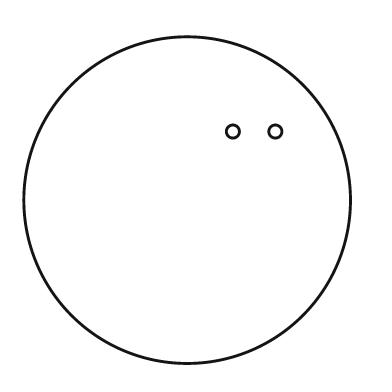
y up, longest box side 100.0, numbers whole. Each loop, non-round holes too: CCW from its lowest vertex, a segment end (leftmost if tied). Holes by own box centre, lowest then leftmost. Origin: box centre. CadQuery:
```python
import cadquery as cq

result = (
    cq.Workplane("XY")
    .moveTo(0.0, 0.0)
    .circle(50.0)
    .moveTo(14.0, 21.0)
    .circle(2.0)
    .moveTo(27.0, 21.0)
    .circle(2.0)
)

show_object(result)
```